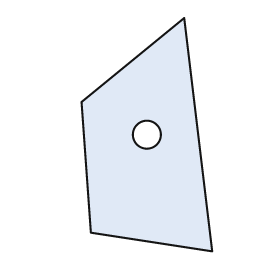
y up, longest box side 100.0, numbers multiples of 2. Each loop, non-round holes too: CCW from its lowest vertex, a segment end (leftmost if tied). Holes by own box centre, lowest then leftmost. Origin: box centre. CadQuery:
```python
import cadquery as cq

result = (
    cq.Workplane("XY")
    .moveTo(28.0, -50.0)
    .lineTo(16.0, 50.0)
    .lineTo(-28.0, 14.0)
    .lineTo(-24.0, -42.0)
    .close()
    .moveTo(0.0, 0.0)
    .circle(6.0)
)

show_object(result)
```